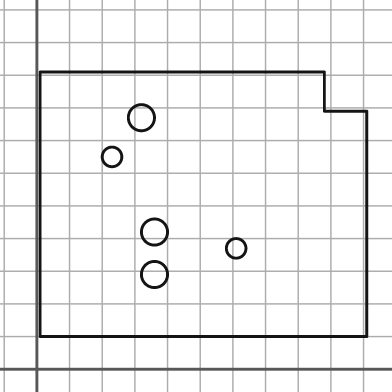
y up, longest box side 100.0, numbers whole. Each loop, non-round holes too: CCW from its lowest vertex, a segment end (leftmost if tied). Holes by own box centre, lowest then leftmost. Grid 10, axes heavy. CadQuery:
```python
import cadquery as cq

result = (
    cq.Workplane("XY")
    .moveTo(1.0, 10.0)
    .lineTo(101.0, 10.0)
    .lineTo(101.0, 79.0)
    .lineTo(88.0, 79.0)
    .lineTo(88.0, 91.0)
    .lineTo(1.0, 91.0)
    .close()
    .moveTo(36.0, 29.0)
    .circle(4.0)
    .moveTo(61.0, 37.0)
    .circle(3.0)
    .moveTo(36.0, 42.0)
    .circle(4.0)
    .moveTo(23.0, 65.0)
    .circle(3.0)
    .moveTo(32.0, 77.0)
    .circle(4.0)
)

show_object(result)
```